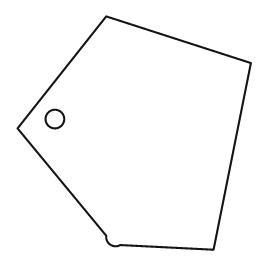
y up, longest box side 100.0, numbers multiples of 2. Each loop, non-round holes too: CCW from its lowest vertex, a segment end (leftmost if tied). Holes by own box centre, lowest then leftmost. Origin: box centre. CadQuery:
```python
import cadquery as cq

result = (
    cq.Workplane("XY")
    .moveTo(34.0, -50.0)
    .lineTo(50.0, 30.0)
    .lineTo(-12.0, 50.0)
    .lineTo(-50.0, 2.0)
    .lineTo(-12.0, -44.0)
    .threePointArc((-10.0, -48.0), (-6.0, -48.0))
    .close()
    .moveTo(-34.0, 6.0)
    .circle(4.0)
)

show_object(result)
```